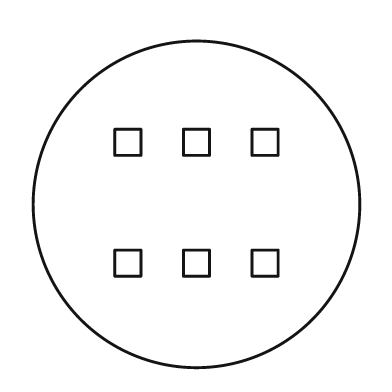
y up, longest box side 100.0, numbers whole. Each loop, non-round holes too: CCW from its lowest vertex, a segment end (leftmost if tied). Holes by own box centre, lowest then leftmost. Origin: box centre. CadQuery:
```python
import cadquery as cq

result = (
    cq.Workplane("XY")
    .moveTo(0.0, 0.0)
    .circle(50.0)
    .moveTo(-25.0, -22.0)
    .lineTo(-17.0, -22.0)
    .lineTo(-17.0, -14.0)
    .lineTo(-25.0, -14.0)
    .close()
    .moveTo(-4.0, -22.0)
    .lineTo(4.0, -22.0)
    .lineTo(4.0, -14.0)
    .lineTo(-4.0, -14.0)
    .close()
    .moveTo(17.0, -22.0)
    .lineTo(25.0, -22.0)
    .lineTo(25.0, -14.0)
    .lineTo(17.0, -14.0)
    .close()
    .moveTo(-25.0, 15.0)
    .lineTo(-17.0, 15.0)
    .lineTo(-17.0, 23.0)
    .lineTo(-25.0, 23.0)
    .close()
    .moveTo(-4.0, 15.0)
    .lineTo(4.0, 15.0)
    .lineTo(4.0, 23.0)
    .lineTo(-4.0, 23.0)
    .close()
    .moveTo(17.0, 15.0)
    .lineTo(25.0, 15.0)
    .lineTo(25.0, 23.0)
    .lineTo(17.0, 23.0)
    .close()
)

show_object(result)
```